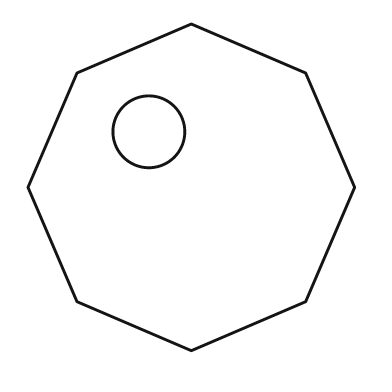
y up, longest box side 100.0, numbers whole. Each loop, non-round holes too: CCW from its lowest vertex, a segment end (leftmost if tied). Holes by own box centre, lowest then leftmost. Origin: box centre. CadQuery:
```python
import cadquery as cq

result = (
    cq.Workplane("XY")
    .moveTo(0.0, -50.0)
    .lineTo(35.0, -35.0)
    .lineTo(50.0, 0.0)
    .lineTo(35.0, 35.0)
    .lineTo(0.0, 50.0)
    .lineTo(-35.0, 35.0)
    .lineTo(-50.0, 0.0)
    .lineTo(-35.0, -35.0)
    .close()
    .moveTo(-13.0, 17.0)
    .circle(11.0)
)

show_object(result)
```